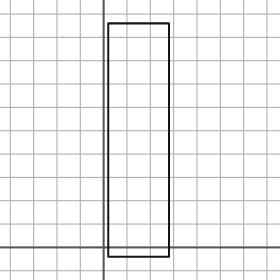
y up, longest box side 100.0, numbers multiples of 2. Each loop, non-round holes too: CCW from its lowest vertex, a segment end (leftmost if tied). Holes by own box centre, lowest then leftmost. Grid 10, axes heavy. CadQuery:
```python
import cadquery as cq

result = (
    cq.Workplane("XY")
    .moveTo(2.0, -4.0)
    .lineTo(28.0, -4.0)
    .lineTo(28.0, 96.0)
    .lineTo(2.0, 96.0)
    .close()
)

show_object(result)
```